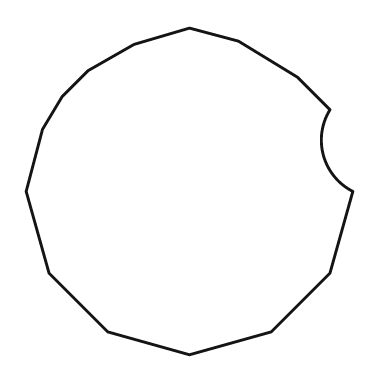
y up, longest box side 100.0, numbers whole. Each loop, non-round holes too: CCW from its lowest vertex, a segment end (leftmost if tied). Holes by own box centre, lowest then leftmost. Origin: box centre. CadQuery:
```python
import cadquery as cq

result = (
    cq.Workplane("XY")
    .moveTo(0.0, -50.0)
    .lineTo(25.0, -43.0)
    .lineTo(43.0, -25.0)
    .lineTo(50.0, 0.0)
    .threePointArc((41.0, 11.0), (43.0, 25.0))
    .lineTo(33.0, 35.0)
    .lineTo(15.0, 46.0)
    .lineTo(0.0, 50.0)
    .lineTo(-17.0, 45.0)
    .lineTo(-31.0, 37.0)
    .lineTo(-39.0, 29.0)
    .lineTo(-45.0, 19.0)
    .lineTo(-50.0, 0.0)
    .lineTo(-43.0, -25.0)
    .lineTo(-25.0, -43.0)
    .close()
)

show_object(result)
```